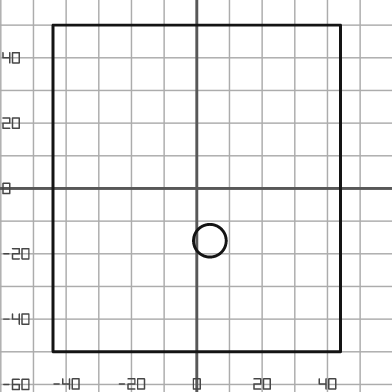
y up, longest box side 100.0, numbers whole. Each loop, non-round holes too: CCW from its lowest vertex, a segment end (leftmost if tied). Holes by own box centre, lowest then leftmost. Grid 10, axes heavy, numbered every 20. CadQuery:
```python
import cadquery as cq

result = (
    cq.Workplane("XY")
    .moveTo(-44.0, -50.0)
    .lineTo(44.0, -50.0)
    .lineTo(44.0, 50.0)
    .lineTo(-44.0, 50.0)
    .close()
    .moveTo(4.0, -16.0)
    .circle(5.0)
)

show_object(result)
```